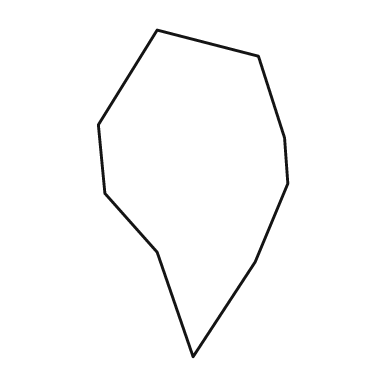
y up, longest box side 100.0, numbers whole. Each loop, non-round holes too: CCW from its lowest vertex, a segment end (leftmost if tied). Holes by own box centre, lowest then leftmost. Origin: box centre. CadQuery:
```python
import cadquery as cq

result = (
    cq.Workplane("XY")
    .moveTo(0.0, -50.0)
    .lineTo(19.0, -21.0)
    .lineTo(29.0, 3.0)
    .lineTo(28.0, 17.0)
    .lineTo(20.0, 42.0)
    .lineTo(-11.0, 50.0)
    .lineTo(-29.0, 21.0)
    .lineTo(-27.0, 0.0)
    .lineTo(-11.0, -18.0)
    .close()
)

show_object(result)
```